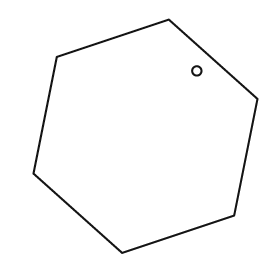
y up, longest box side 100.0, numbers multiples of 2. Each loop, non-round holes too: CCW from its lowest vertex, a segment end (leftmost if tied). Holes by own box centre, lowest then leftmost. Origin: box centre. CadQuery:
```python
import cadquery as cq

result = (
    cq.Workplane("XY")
    .moveTo(-10.0, -50.0)
    .lineTo(38.0, -34.0)
    .lineTo(48.0, 16.0)
    .lineTo(10.0, 50.0)
    .lineTo(-38.0, 34.0)
    .lineTo(-48.0, -16.0)
    .close()
    .moveTo(22.0, 28.0)
    .circle(2.0)
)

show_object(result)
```